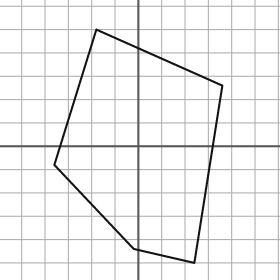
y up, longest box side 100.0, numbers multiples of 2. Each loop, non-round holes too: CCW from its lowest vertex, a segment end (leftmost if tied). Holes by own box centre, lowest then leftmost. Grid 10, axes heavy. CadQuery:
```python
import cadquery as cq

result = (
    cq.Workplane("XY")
    .moveTo(24.0, -50.0)
    .lineTo(36.0, 26.0)
    .lineTo(-18.0, 50.0)
    .lineTo(-36.0, -8.0)
    .lineTo(-2.0, -44.0)
    .close()
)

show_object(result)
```